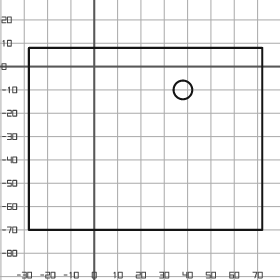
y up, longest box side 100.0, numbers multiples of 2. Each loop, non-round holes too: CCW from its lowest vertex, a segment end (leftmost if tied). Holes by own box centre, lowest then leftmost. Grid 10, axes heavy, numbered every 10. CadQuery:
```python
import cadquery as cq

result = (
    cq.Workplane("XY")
    .moveTo(-28.0, -70.0)
    .lineTo(72.0, -70.0)
    .lineTo(72.0, 8.0)
    .lineTo(-28.0, 8.0)
    .close()
    .moveTo(38.0, -10.0)
    .circle(4.0)
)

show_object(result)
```